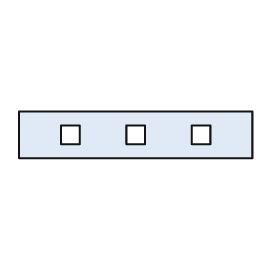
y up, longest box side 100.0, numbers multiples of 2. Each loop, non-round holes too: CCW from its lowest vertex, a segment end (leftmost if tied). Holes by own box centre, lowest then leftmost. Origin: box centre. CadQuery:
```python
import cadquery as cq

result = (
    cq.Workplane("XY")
    .moveTo(-50.0, -10.0)
    .lineTo(50.0, -10.0)
    .lineTo(50.0, 10.0)
    .lineTo(-50.0, 10.0)
    .close()
    .moveTo(-32.0, -4.0)
    .lineTo(-24.0, -4.0)
    .lineTo(-24.0, 4.0)
    .lineTo(-32.0, 4.0)
    .close()
    .moveTo(-4.0, -4.0)
    .lineTo(4.0, -4.0)
    .lineTo(4.0, 4.0)
    .lineTo(-4.0, 4.0)
    .close()
    .moveTo(24.0, -4.0)
    .lineTo(32.0, -4.0)
    .lineTo(32.0, 4.0)
    .lineTo(24.0, 4.0)
    .close()
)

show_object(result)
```